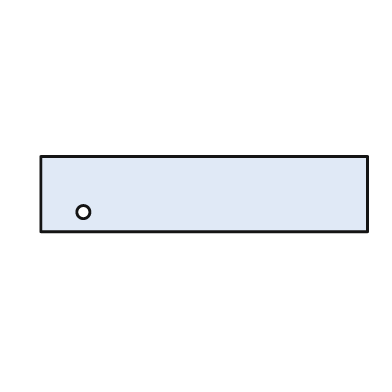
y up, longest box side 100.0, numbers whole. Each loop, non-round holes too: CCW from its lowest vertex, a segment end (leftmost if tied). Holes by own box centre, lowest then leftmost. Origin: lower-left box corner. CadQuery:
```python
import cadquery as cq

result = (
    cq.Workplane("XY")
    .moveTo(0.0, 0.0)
    .lineTo(100.0, 0.0)
    .lineTo(100.0, 23.0)
    .lineTo(0.0, 23.0)
    .close()
    .moveTo(13.0, 6.0)
    .circle(2.0)
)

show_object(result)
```